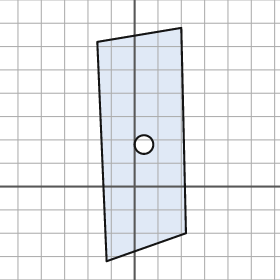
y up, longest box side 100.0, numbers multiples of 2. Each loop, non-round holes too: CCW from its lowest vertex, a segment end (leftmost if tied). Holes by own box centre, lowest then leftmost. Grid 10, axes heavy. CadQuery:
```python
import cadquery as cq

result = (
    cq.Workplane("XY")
    .moveTo(-12.0, -32.0)
    .lineTo(22.0, -20.0)
    .lineTo(20.0, 68.0)
    .lineTo(-16.0, 62.0)
    .close()
    .moveTo(4.0, 18.0)
    .circle(4.0)
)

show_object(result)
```